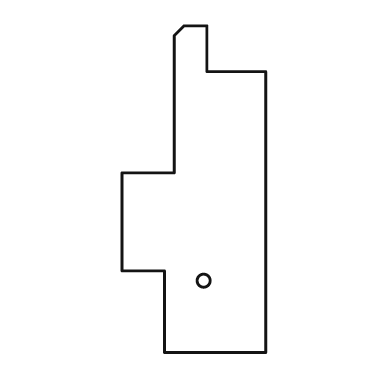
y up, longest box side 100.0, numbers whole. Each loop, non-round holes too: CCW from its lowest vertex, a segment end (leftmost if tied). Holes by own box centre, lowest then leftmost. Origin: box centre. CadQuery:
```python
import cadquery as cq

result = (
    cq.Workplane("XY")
    .moveTo(-9.0, -50.0)
    .lineTo(22.0, -50.0)
    .lineTo(22.0, 36.0)
    .lineTo(4.0, 36.0)
    .lineTo(4.0, 50.0)
    .lineTo(-3.0, 50.0)
    .lineTo(-6.0, 47.0)
    .lineTo(-6.0, 5.0)
    .lineTo(-22.0, 5.0)
    .lineTo(-22.0, -25.0)
    .lineTo(-9.0, -25.0)
    .close()
    .moveTo(3.0, -28.0)
    .circle(2.0)
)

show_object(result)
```